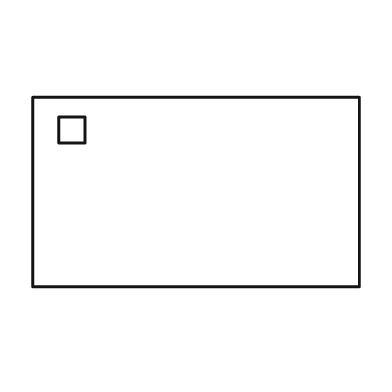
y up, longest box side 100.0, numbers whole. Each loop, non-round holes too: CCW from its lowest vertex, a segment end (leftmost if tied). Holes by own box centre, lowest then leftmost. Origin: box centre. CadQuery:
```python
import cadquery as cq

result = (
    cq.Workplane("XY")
    .moveTo(-50.0, -29.0)
    .lineTo(50.0, -29.0)
    .lineTo(50.0, 29.0)
    .lineTo(-50.0, 29.0)
    .close()
    .moveTo(-42.0, 15.0)
    .lineTo(-34.0, 15.0)
    .lineTo(-34.0, 23.0)
    .lineTo(-42.0, 23.0)
    .close()
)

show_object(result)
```